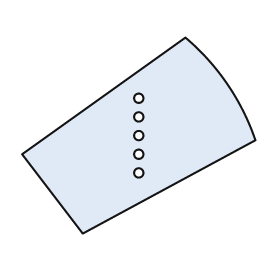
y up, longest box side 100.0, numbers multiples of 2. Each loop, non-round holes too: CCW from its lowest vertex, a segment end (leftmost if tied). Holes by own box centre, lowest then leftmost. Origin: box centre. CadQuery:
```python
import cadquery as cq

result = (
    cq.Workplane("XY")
    .moveTo(-24.0, -42.0)
    .lineTo(50.0, -2.0)
    .threePointArc((38.0, 22.0), (20.0, 42.0))
    .lineTo(-50.0, -8.0)
    .close()
    .moveTo(0.0, -16.0)
    .circle(2.0)
    .moveTo(0.0, -8.0)
    .circle(2.0)
    .moveTo(0.0, 0.0)
    .circle(2.0)
    .moveTo(0.0, 8.0)
    .circle(2.0)
    .moveTo(0.0, 16.0)
    .circle(2.0)
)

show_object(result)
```